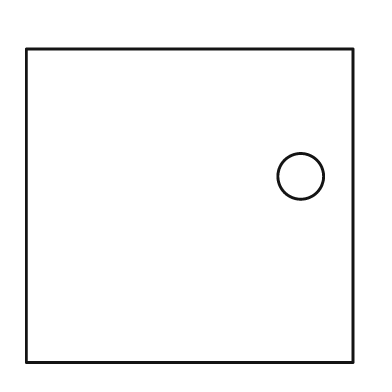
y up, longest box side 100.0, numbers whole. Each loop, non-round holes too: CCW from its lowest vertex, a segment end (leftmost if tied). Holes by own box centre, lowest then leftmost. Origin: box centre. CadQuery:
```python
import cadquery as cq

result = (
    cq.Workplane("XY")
    .moveTo(-50.0, -48.0)
    .lineTo(50.0, -48.0)
    .lineTo(50.0, 48.0)
    .lineTo(-50.0, 48.0)
    .close()
    .moveTo(34.0, 9.0)
    .circle(7.0)
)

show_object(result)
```